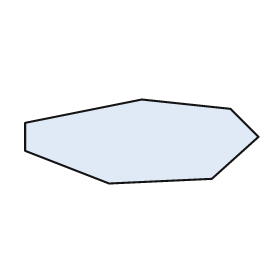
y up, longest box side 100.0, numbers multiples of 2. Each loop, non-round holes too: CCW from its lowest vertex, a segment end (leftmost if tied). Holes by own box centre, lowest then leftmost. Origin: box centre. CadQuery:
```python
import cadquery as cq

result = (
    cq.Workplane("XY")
    .moveTo(-14.0, -18.0)
    .lineTo(30.0, -16.0)
    .lineTo(50.0, 2.0)
    .lineTo(38.0, 14.0)
    .lineTo(0.0, 18.0)
    .lineTo(-50.0, 8.0)
    .lineTo(-50.0, -4.0)
    .close()
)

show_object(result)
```